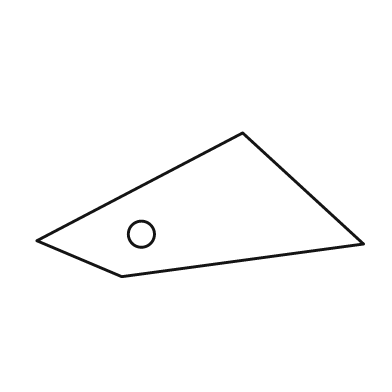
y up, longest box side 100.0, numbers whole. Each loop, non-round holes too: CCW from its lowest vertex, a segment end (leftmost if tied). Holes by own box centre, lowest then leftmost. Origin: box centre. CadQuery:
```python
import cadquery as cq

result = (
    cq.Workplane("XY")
    .moveTo(-24.0, -22.0)
    .lineTo(50.0, -12.0)
    .lineTo(13.0, 22.0)
    .lineTo(-50.0, -11.0)
    .close()
    .moveTo(-18.0, -9.0)
    .circle(4.0)
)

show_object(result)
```